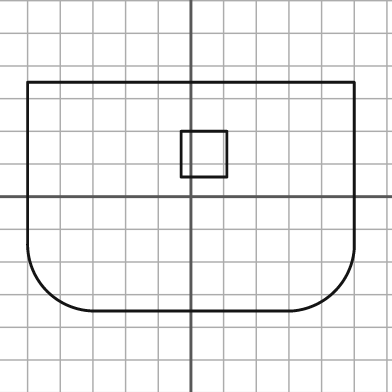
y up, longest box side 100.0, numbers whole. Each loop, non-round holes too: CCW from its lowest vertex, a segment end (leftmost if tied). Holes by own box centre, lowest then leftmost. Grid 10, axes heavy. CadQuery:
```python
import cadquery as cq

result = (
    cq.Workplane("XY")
    .moveTo(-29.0, -35.0)
    .lineTo(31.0, -35.0)
    .threePointArc((44.0, -29.0), (50.0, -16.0))
    .lineTo(50.0, 35.0)
    .lineTo(-50.0, 35.0)
    .lineTo(-50.0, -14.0)
    .threePointArc((-44.0, -29.0), (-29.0, -35.0))
    .close()
    .moveTo(-3.0, 6.0)
    .lineTo(11.0, 6.0)
    .lineTo(11.0, 20.0)
    .lineTo(-3.0, 20.0)
    .close()
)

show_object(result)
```